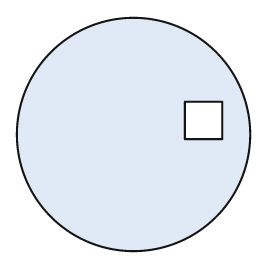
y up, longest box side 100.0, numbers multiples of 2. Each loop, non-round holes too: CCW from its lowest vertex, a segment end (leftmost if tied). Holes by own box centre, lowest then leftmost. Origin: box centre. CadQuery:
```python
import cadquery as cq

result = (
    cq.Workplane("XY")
    .moveTo(0.0, 0.0)
    .circle(50.0)
    .moveTo(22.0, -2.0)
    .lineTo(38.0, -2.0)
    .lineTo(38.0, 14.0)
    .lineTo(22.0, 14.0)
    .close()
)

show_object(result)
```